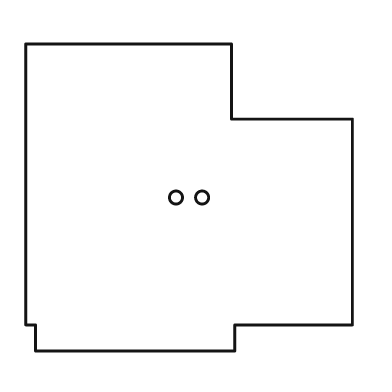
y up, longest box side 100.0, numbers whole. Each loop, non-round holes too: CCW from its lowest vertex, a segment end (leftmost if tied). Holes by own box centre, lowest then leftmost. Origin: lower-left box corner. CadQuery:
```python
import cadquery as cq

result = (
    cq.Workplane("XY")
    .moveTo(3.0, 0.0)
    .lineTo(64.0, 0.0)
    .lineTo(64.0, 8.0)
    .lineTo(100.0, 8.0)
    .lineTo(100.0, 71.0)
    .lineTo(63.0, 71.0)
    .lineTo(63.0, 94.0)
    .lineTo(0.0, 94.0)
    .lineTo(0.0, 8.0)
    .lineTo(3.0, 8.0)
    .close()
    .moveTo(46.0, 47.0)
    .circle(2.0)
    .moveTo(54.0, 47.0)
    .circle(2.0)
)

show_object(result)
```